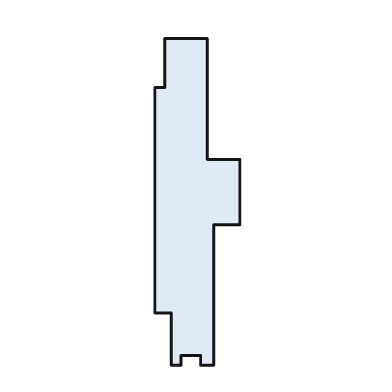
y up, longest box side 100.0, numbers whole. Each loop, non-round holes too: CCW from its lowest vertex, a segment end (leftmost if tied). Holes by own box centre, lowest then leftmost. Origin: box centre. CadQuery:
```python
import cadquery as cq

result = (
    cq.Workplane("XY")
    .moveTo(-8.0, -50.0)
    .lineTo(-5.0, -50.0)
    .lineTo(-5.0, -47.0)
    .lineTo(1.0, -47.0)
    .lineTo(1.0, -50.0)
    .lineTo(5.0, -50.0)
    .lineTo(5.0, -7.0)
    .lineTo(13.0, -7.0)
    .lineTo(13.0, 13.0)
    .lineTo(3.0, 13.0)
    .lineTo(3.0, 50.0)
    .lineTo(-10.0, 50.0)
    .lineTo(-10.0, 35.0)
    .lineTo(-13.0, 35.0)
    .lineTo(-13.0, -34.0)
    .lineTo(-8.0, -34.0)
    .close()
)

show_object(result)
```